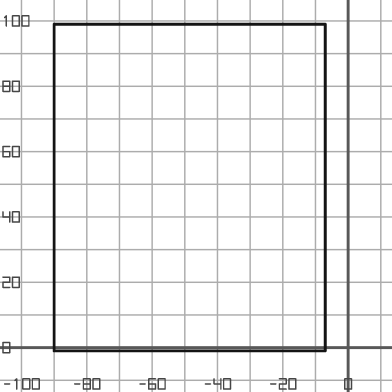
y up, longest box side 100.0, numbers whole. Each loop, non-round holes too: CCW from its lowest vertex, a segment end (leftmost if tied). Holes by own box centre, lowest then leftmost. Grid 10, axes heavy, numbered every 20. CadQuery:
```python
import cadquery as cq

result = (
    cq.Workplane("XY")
    .moveTo(-90.0, -1.0)
    .lineTo(-7.0, -1.0)
    .lineTo(-7.0, 99.0)
    .lineTo(-90.0, 99.0)
    .close()
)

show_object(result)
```